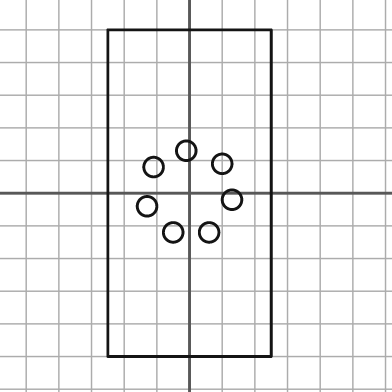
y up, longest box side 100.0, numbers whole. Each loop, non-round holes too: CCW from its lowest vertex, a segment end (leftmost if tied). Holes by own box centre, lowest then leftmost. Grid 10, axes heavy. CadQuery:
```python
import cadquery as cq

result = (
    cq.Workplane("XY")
    .moveTo(-25.0, -50.0)
    .lineTo(25.0, -50.0)
    .lineTo(25.0, 50.0)
    .lineTo(-25.0, 50.0)
    .close()
    .moveTo(-5.0, -12.0)
    .circle(3.0)
    .moveTo(6.0, -12.0)
    .circle(3.0)
    .moveTo(-13.0, -4.0)
    .circle(3.0)
    .moveTo(13.0, -2.0)
    .circle(3.0)
    .moveTo(-11.0, 8.0)
    .circle(3.0)
    .moveTo(10.0, 9.0)
    .circle(3.0)
    .moveTo(-1.0, 13.0)
    .circle(3.0)
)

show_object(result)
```